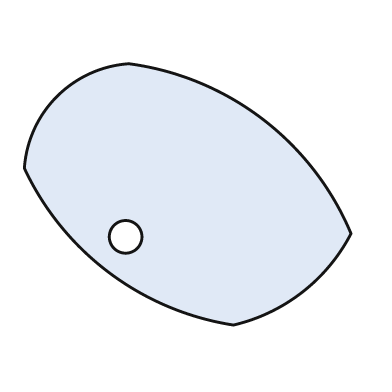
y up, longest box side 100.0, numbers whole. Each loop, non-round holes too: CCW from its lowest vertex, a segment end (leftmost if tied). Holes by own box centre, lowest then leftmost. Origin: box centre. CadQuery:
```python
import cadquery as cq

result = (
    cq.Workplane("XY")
    .moveTo(14.0, -40.0)
    .threePointArc((35.0, -30.0), (50.0, -12.0))
    .threePointArc((23.0, 23.0), (-18.0, 40.0))
    .threePointArc((-40.0, 30.0), (-50.0, 8.0))
    .threePointArc((-24.0, -24.0), (14.0, -40.0))
    .close()
    .moveTo(-19.0, -13.0)
    .circle(5.0)
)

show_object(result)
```